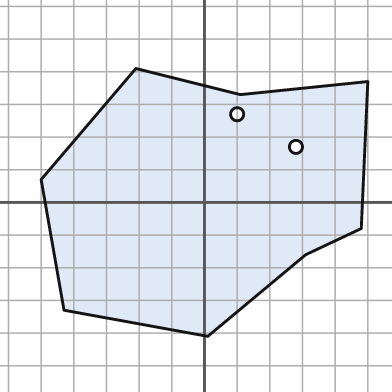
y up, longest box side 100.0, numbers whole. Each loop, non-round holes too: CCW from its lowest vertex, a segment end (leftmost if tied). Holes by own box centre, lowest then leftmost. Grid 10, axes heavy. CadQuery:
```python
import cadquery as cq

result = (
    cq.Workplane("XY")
    .moveTo(1.0, -41.0)
    .lineTo(31.0, -16.0)
    .lineTo(48.0, -8.0)
    .lineTo(50.0, 37.0)
    .lineTo(11.0, 33.0)
    .lineTo(-21.0, 41.0)
    .lineTo(-50.0, 7.0)
    .lineTo(-43.0, -33.0)
    .close()
    .moveTo(28.0, 17.0)
    .circle(2.0)
    .moveTo(10.0, 27.0)
    .circle(2.0)
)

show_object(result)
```